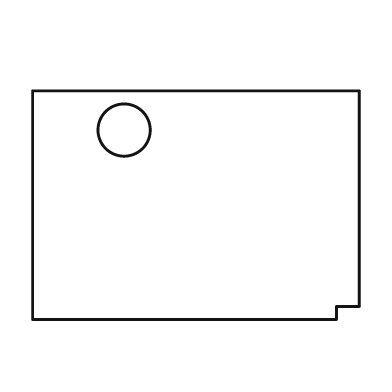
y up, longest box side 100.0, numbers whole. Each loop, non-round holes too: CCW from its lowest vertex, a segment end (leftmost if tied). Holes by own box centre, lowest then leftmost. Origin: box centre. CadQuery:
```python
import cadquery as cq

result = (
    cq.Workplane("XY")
    .moveTo(-50.0, -35.0)
    .lineTo(43.0, -35.0)
    .lineTo(43.0, -31.0)
    .lineTo(50.0, -31.0)
    .lineTo(50.0, 35.0)
    .lineTo(-50.0, 35.0)
    .close()
    .moveTo(-22.0, 23.0)
    .circle(8.0)
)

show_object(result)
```